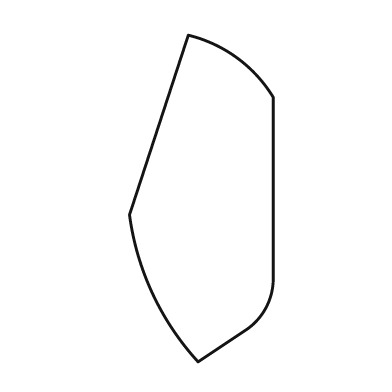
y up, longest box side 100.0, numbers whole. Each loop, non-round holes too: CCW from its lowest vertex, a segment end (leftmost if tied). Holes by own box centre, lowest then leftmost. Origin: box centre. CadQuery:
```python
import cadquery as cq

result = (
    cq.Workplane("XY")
    .moveTo(-1.0, -50.0)
    .lineTo(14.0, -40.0)
    .threePointArc((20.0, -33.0), (22.0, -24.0))
    .lineTo(22.0, 31.0)
    .threePointArc((11.0, 43.0), (-4.0, 50.0))
    .lineTo(-22.0, -5.0)
    .threePointArc((-15.0, -29.0), (-1.0, -50.0))
    .close()
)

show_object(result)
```